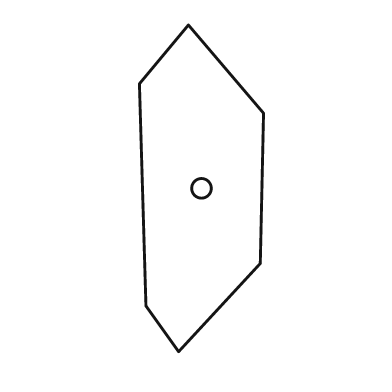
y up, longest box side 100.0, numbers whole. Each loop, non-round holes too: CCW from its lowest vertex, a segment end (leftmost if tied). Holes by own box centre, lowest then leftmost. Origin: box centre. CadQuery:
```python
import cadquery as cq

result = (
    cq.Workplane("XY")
    .moveTo(-7.0, -50.0)
    .lineTo(18.0, -23.0)
    .lineTo(19.0, 23.0)
    .lineTo(-4.0, 50.0)
    .lineTo(-19.0, 32.0)
    .lineTo(-17.0, -36.0)
    .close()
    .moveTo(0.0, 0.0)
    .circle(3.0)
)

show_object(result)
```